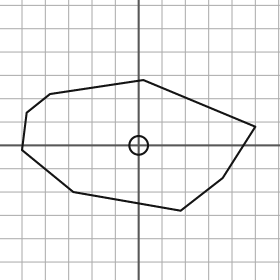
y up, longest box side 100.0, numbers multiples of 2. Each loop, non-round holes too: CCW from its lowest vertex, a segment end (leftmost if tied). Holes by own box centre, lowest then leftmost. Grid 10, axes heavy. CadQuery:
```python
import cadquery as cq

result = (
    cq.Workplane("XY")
    .moveTo(18.0, -28.0)
    .lineTo(36.0, -14.0)
    .lineTo(50.0, 8.0)
    .lineTo(2.0, 28.0)
    .lineTo(-38.0, 22.0)
    .lineTo(-48.0, 14.0)
    .lineTo(-50.0, -2.0)
    .lineTo(-28.0, -20.0)
    .close()
    .moveTo(0.0, 0.0)
    .circle(4.0)
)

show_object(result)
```